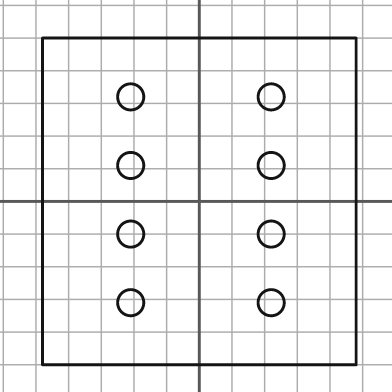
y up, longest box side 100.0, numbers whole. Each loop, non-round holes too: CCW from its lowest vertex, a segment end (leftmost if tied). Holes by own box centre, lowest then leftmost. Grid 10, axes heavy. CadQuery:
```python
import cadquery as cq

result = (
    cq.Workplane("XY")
    .moveTo(-48.0, -50.0)
    .lineTo(48.0, -50.0)
    .lineTo(48.0, 50.0)
    .lineTo(-48.0, 50.0)
    .close()
    .moveTo(-21.0, -31.0)
    .circle(4.0)
    .moveTo(22.0, -31.0)
    .circle(4.0)
    .moveTo(-21.0, -10.0)
    .circle(4.0)
    .moveTo(22.0, -10.0)
    .circle(4.0)
    .moveTo(-21.0, 11.0)
    .circle(4.0)
    .moveTo(22.0, 11.0)
    .circle(4.0)
    .moveTo(-21.0, 32.0)
    .circle(4.0)
    .moveTo(22.0, 32.0)
    .circle(4.0)
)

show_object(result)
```